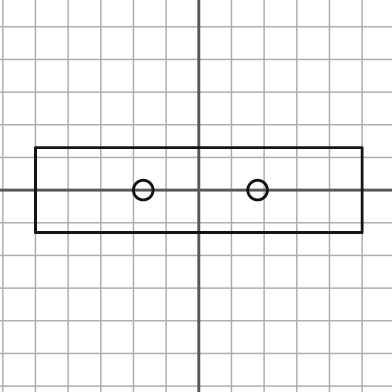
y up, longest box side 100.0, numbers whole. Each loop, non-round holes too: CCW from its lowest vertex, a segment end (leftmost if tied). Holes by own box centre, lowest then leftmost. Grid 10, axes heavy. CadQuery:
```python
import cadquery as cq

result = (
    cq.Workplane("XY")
    .moveTo(-50.0, -13.0)
    .lineTo(50.0, -13.0)
    .lineTo(50.0, 13.0)
    .lineTo(-50.0, 13.0)
    .close()
    .moveTo(-17.0, 0.0)
    .circle(3.0)
    .moveTo(18.0, 0.0)
    .circle(3.0)
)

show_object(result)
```